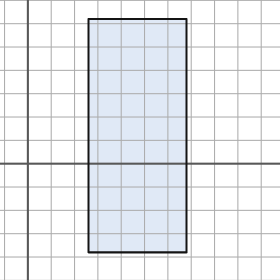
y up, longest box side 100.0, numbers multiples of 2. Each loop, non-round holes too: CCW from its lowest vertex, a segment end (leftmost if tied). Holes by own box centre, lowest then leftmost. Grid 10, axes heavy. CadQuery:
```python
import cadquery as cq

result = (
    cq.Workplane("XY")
    .moveTo(26.0, -38.0)
    .lineTo(68.0, -38.0)
    .lineTo(68.0, 62.0)
    .lineTo(26.0, 62.0)
    .close()
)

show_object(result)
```